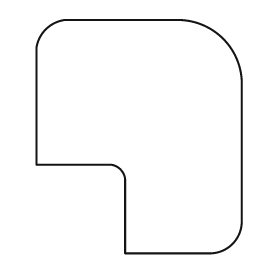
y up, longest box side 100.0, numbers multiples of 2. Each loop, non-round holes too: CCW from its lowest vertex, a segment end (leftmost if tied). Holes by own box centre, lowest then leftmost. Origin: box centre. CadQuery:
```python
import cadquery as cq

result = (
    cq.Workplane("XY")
    .moveTo(-6.0, -50.0)
    .lineTo(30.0, -50.0)
    .threePointArc((40.0, -46.0), (44.0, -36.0))
    .lineTo(44.0, 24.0)
    .threePointArc((36.0, 42.0), (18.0, 50.0))
    .lineTo(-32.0, 50.0)
    .threePointArc((-40.0, 46.0), (-44.0, 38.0))
    .lineTo(-44.0, -12.0)
    .lineTo(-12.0, -12.0)
    .threePointArc((-8.0, -14.0), (-6.0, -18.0))
    .close()
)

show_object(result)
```